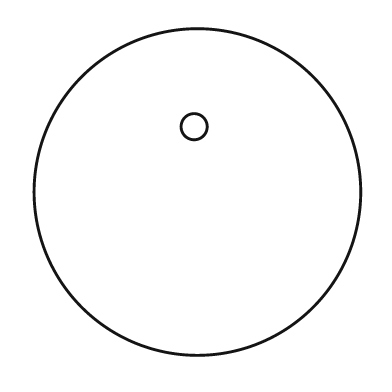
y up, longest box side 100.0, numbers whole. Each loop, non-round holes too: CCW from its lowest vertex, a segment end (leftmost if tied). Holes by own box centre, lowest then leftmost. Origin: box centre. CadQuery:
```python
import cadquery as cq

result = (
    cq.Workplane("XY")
    .moveTo(0.0, 0.0)
    .circle(50.0)
    .moveTo(-1.0, 20.0)
    .circle(4.0)
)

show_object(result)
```